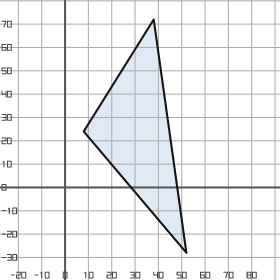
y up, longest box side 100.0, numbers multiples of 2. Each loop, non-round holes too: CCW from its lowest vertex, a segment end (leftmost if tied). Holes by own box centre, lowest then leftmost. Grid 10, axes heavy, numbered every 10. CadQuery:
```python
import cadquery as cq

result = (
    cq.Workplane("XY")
    .moveTo(52.0, -28.0)
    .lineTo(38.0, 72.0)
    .lineTo(8.0, 24.0)
    .close()
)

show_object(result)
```